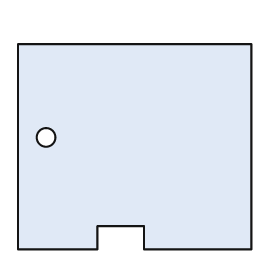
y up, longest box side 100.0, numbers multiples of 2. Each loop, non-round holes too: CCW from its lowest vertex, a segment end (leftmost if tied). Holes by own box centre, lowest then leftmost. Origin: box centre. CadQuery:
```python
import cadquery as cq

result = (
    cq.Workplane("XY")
    .moveTo(-50.0, -44.0)
    .lineTo(-16.0, -44.0)
    .lineTo(-16.0, -34.0)
    .lineTo(4.0, -34.0)
    .lineTo(4.0, -44.0)
    .lineTo(50.0, -44.0)
    .lineTo(50.0, 44.0)
    .lineTo(-50.0, 44.0)
    .close()
    .moveTo(-38.0, 4.0)
    .circle(4.0)
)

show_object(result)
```